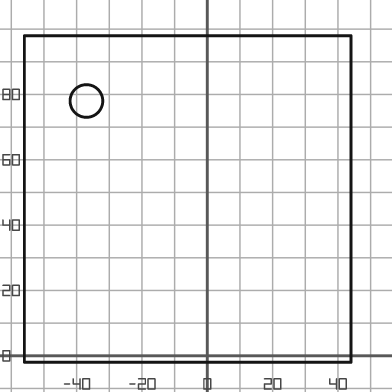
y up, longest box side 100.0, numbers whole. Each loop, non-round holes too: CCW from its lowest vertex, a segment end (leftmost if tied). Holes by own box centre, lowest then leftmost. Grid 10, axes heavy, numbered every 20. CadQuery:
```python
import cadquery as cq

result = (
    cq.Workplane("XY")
    .moveTo(-56.0, -2.0)
    .lineTo(44.0, -2.0)
    .lineTo(44.0, 98.0)
    .lineTo(-56.0, 98.0)
    .close()
    .moveTo(-37.0, 78.0)
    .circle(5.0)
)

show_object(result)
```